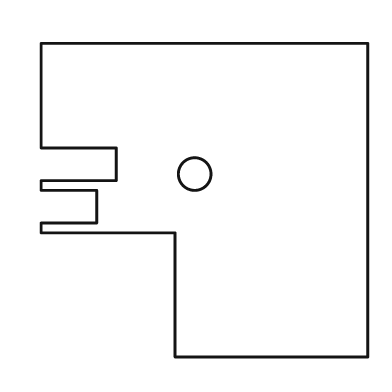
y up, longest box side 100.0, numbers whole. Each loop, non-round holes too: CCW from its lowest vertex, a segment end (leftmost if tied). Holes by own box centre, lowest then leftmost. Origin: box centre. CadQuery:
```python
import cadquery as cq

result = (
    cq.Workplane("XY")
    .moveTo(-9.0, -48.0)
    .lineTo(50.0, -48.0)
    .lineTo(50.0, 48.0)
    .lineTo(-50.0, 48.0)
    .lineTo(-50.0, 16.0)
    .lineTo(-27.0, 16.0)
    .lineTo(-27.0, 6.0)
    .lineTo(-50.0, 6.0)
    .lineTo(-50.0, 3.0)
    .lineTo(-33.0, 3.0)
    .lineTo(-33.0, -7.0)
    .lineTo(-50.0, -7.0)
    .lineTo(-50.0, -10.0)
    .lineTo(-9.0, -10.0)
    .close()
    .moveTo(-3.0, 8.0)
    .circle(5.0)
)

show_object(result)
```